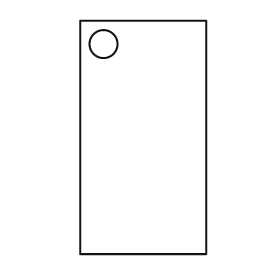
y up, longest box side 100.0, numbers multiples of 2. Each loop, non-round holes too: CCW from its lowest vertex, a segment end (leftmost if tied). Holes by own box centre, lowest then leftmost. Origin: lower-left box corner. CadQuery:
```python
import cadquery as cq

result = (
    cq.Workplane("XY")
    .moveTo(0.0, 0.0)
    .lineTo(54.0, 0.0)
    .lineTo(54.0, 100.0)
    .lineTo(0.0, 100.0)
    .close()
    .moveTo(10.0, 90.0)
    .circle(6.0)
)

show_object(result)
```